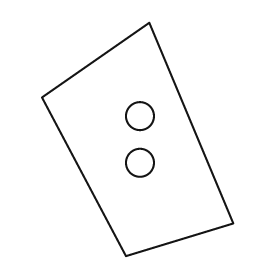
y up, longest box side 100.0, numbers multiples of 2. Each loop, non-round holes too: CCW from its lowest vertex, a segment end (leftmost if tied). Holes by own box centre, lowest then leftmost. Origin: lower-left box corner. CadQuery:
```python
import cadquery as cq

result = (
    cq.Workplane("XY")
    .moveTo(36.0, 0.0)
    .lineTo(82.0, 14.0)
    .lineTo(46.0, 100.0)
    .lineTo(0.0, 68.0)
    .close()
    .moveTo(42.0, 40.0)
    .circle(6.0)
    .moveTo(42.0, 60.0)
    .circle(6.0)
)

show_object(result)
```